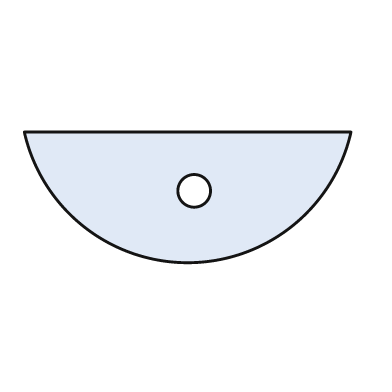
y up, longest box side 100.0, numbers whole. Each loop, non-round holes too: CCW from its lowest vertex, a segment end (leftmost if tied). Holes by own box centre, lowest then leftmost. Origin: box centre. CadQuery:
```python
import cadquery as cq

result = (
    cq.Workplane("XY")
    .moveTo(-50.0, 20.0)
    .threePointArc((0.0, -20.0), (50.0, 20.0))
    .close()
    .moveTo(2.0, 2.0)
    .circle(5.0)
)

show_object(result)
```